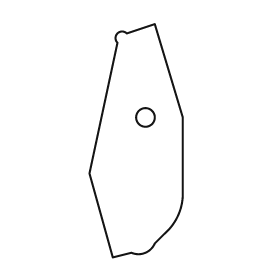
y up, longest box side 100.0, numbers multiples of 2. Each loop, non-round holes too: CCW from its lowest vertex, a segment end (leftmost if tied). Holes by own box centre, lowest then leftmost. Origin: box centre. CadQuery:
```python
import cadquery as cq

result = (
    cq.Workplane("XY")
    .moveTo(-10.0, -50.0)
    .lineTo(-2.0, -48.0)
    .threePointArc((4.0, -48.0), (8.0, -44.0))
    .lineTo(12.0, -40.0)
    .threePointArc((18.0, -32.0), (20.0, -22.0))
    .lineTo(20.0, 10.0)
    .lineTo(8.0, 50.0)
    .lineTo(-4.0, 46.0)
    .threePointArc((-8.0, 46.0), (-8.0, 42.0))
    .lineTo(-20.0, -14.0)
    .close()
    .moveTo(4.0, 10.0)
    .circle(4.0)
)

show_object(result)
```